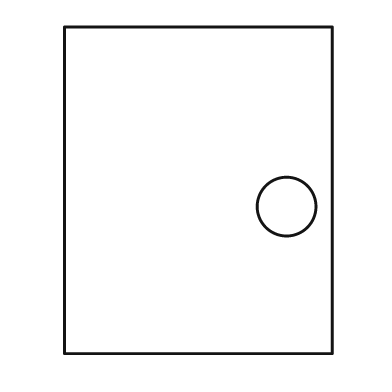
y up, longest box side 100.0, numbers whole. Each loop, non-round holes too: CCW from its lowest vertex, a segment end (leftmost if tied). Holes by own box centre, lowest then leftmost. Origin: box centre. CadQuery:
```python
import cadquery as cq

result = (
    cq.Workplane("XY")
    .moveTo(-41.0, -50.0)
    .lineTo(41.0, -50.0)
    .lineTo(41.0, 50.0)
    .lineTo(-41.0, 50.0)
    .close()
    .moveTo(27.0, -5.0)
    .circle(9.0)
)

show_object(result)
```